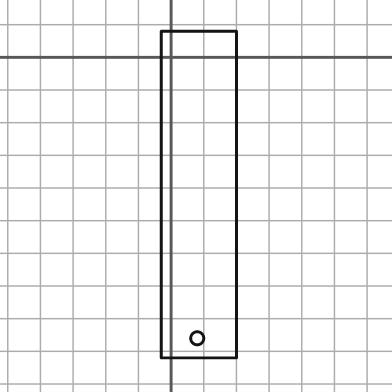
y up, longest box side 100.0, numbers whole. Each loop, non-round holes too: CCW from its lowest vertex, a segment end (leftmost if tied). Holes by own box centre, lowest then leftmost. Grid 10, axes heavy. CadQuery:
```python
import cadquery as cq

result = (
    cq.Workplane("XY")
    .moveTo(-3.0, -92.0)
    .lineTo(20.0, -92.0)
    .lineTo(20.0, 8.0)
    .lineTo(-3.0, 8.0)
    .close()
    .moveTo(8.0, -86.0)
    .circle(2.0)
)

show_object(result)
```